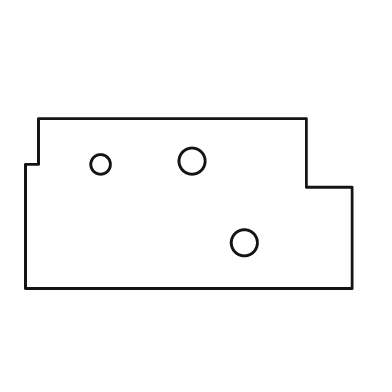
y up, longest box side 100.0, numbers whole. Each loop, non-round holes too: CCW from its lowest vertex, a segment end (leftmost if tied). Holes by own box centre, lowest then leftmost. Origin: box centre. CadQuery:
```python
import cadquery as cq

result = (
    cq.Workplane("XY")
    .moveTo(-50.0, -26.0)
    .lineTo(50.0, -26.0)
    .lineTo(50.0, 5.0)
    .lineTo(36.0, 5.0)
    .lineTo(36.0, 26.0)
    .lineTo(-46.0, 26.0)
    .lineTo(-46.0, 12.0)
    .lineTo(-50.0, 12.0)
    .close()
    .moveTo(17.0, -12.0)
    .circle(4.0)
    .moveTo(-27.0, 12.0)
    .circle(3.0)
    .moveTo(1.0, 13.0)
    .circle(4.0)
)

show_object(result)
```